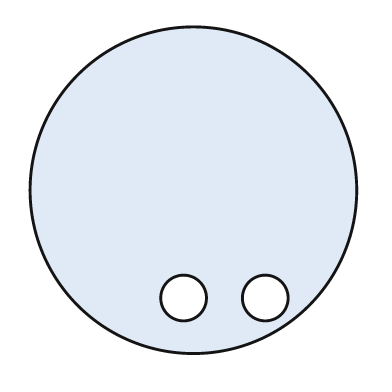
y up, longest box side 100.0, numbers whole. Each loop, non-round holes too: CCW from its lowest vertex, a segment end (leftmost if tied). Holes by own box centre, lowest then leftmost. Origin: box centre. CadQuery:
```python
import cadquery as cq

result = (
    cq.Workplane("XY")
    .moveTo(0.0, 0.0)
    .circle(50.0)
    .moveTo(-3.0, -33.0)
    .circle(7.0)
    .moveTo(22.0, -33.0)
    .circle(7.0)
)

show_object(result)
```